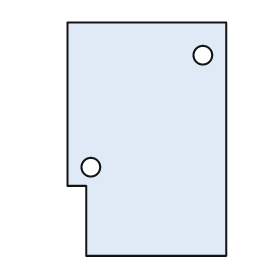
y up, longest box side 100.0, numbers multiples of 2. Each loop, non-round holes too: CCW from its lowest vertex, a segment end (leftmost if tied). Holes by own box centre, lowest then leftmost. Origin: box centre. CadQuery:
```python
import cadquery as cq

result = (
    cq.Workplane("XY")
    .moveTo(-26.0, -50.0)
    .lineTo(34.0, -50.0)
    .lineTo(34.0, 50.0)
    .lineTo(-34.0, 50.0)
    .lineTo(-34.0, -20.0)
    .lineTo(-26.0, -20.0)
    .close()
    .moveTo(-24.0, -12.0)
    .circle(4.0)
    .moveTo(24.0, 36.0)
    .circle(4.0)
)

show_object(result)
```